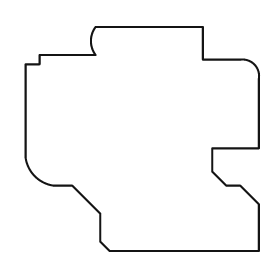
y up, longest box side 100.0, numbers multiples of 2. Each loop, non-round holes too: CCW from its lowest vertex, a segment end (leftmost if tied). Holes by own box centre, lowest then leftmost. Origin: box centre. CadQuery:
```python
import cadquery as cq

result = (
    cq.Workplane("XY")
    .moveTo(-14.0, -48.0)
    .lineTo(50.0, -48.0)
    .lineTo(50.0, -28.0)
    .lineTo(42.0, -20.0)
    .lineTo(36.0, -20.0)
    .lineTo(30.0, -14.0)
    .lineTo(30.0, -4.0)
    .lineTo(50.0, -4.0)
    .lineTo(50.0, 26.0)
    .threePointArc((48.0, 32.0), (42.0, 34.0))
    .lineTo(26.0, 34.0)
    .lineTo(26.0, 48.0)
    .lineTo(-20.0, 48.0)
    .threePointArc((-22.0, 42.0), (-20.0, 36.0))
    .lineTo(-44.0, 36.0)
    .lineTo(-44.0, 32.0)
    .lineTo(-50.0, 32.0)
    .lineTo(-50.0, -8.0)
    .threePointArc((-46.0, -16.0), (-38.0, -20.0))
    .lineTo(-30.0, -20.0)
    .lineTo(-18.0, -32.0)
    .lineTo(-18.0, -44.0)
    .close()
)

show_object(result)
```